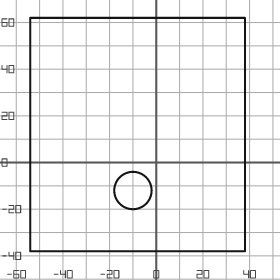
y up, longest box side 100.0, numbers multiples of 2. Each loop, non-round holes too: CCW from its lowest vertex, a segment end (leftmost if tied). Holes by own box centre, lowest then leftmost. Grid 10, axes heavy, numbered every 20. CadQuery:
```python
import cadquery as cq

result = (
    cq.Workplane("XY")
    .moveTo(-54.0, -38.0)
    .lineTo(38.0, -38.0)
    .lineTo(38.0, 62.0)
    .lineTo(-54.0, 62.0)
    .close()
    .moveTo(-10.0, -12.0)
    .circle(8.0)
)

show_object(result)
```